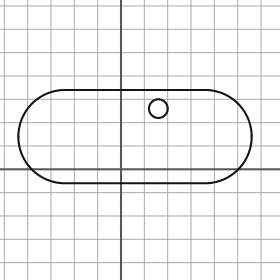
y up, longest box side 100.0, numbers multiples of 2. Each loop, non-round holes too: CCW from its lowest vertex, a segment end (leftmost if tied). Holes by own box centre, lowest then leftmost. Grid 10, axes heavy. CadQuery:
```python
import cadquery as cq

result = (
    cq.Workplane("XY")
    .moveTo(-24.0, -6.0)
    .lineTo(36.0, -6.0)
    .threePointArc((56.0, 14.0), (36.0, 34.0))
    .lineTo(-24.0, 34.0)
    .threePointArc((-44.0, 14.0), (-24.0, -6.0))
    .close()
    .moveTo(16.0, 26.0)
    .circle(4.0)
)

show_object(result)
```